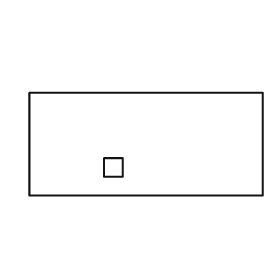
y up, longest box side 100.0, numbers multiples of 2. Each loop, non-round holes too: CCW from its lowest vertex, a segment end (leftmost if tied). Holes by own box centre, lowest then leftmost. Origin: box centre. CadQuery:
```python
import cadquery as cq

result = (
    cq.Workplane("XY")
    .moveTo(-50.0, -22.0)
    .lineTo(50.0, -22.0)
    .lineTo(50.0, 22.0)
    .lineTo(-50.0, 22.0)
    .close()
    .moveTo(-18.0, -14.0)
    .lineTo(-10.0, -14.0)
    .lineTo(-10.0, -6.0)
    .lineTo(-18.0, -6.0)
    .close()
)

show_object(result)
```